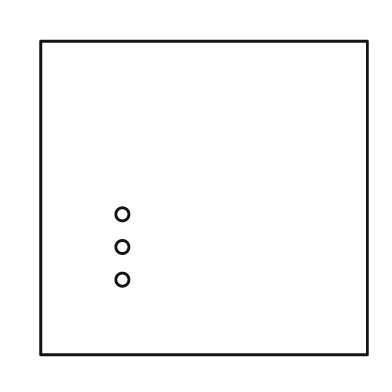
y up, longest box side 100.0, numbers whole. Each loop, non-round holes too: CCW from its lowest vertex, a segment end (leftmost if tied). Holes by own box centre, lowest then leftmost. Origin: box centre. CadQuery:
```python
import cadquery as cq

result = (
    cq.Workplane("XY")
    .moveTo(-50.0, -48.0)
    .lineTo(50.0, -48.0)
    .lineTo(50.0, 48.0)
    .lineTo(-50.0, 48.0)
    .close()
    .moveTo(-25.0, -25.0)
    .circle(2.0)
    .moveTo(-25.0, -15.0)
    .circle(2.0)
    .moveTo(-25.0, -5.0)
    .circle(2.0)
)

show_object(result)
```